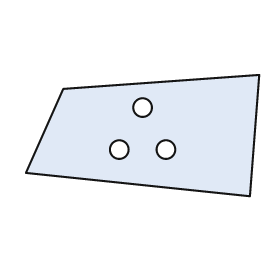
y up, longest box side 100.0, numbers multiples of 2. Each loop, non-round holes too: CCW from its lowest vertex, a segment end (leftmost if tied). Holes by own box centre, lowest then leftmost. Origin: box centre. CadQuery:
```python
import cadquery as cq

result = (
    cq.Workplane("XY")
    .moveTo(46.0, -26.0)
    .lineTo(50.0, 26.0)
    .lineTo(-34.0, 20.0)
    .lineTo(-50.0, -16.0)
    .close()
    .moveTo(-10.0, -6.0)
    .circle(4.0)
    .moveTo(10.0, -6.0)
    .circle(4.0)
    .moveTo(0.0, 12.0)
    .circle(4.0)
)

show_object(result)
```